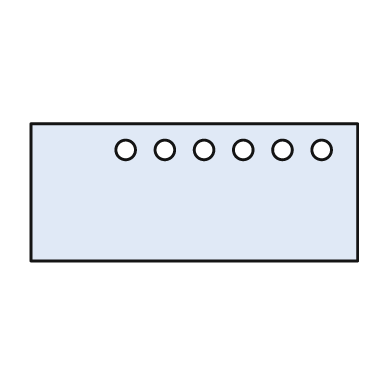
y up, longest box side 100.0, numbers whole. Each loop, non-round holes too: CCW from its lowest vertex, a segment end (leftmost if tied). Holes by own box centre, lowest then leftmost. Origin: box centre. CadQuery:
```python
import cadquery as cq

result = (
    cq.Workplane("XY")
    .moveTo(-50.0, -21.0)
    .lineTo(50.0, -21.0)
    .lineTo(50.0, 21.0)
    .lineTo(-50.0, 21.0)
    .close()
    .moveTo(-21.0, 13.0)
    .circle(3.0)
    .moveTo(-9.0, 13.0)
    .circle(3.0)
    .moveTo(3.0, 13.0)
    .circle(3.0)
    .moveTo(15.0, 13.0)
    .circle(3.0)
    .moveTo(27.0, 13.0)
    .circle(3.0)
    .moveTo(39.0, 13.0)
    .circle(3.0)
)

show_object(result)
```